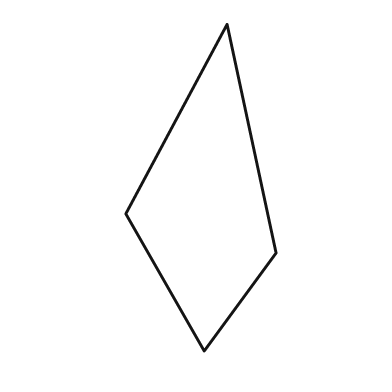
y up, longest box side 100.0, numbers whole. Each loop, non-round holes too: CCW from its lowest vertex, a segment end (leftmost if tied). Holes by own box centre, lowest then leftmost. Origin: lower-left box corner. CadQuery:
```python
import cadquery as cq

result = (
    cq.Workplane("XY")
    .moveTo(24.0, 0.0)
    .lineTo(46.0, 30.0)
    .lineTo(31.0, 100.0)
    .lineTo(0.0, 42.0)
    .close()
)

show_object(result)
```